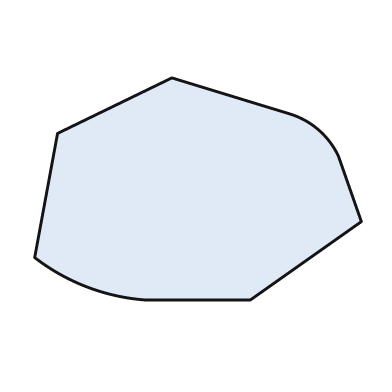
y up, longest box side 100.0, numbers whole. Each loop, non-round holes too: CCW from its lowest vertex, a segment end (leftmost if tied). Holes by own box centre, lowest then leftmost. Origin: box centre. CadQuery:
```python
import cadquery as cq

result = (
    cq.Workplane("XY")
    .moveTo(-16.0, -34.0)
    .lineTo(16.0, -34.0)
    .lineTo(50.0, -10.0)
    .lineTo(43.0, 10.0)
    .threePointArc((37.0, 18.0), (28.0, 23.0))
    .lineTo(-8.0, 34.0)
    .lineTo(-43.0, 17.0)
    .lineTo(-50.0, -21.0)
    .threePointArc((-34.0, -30.0), (-16.0, -34.0))
    .close()
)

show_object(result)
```